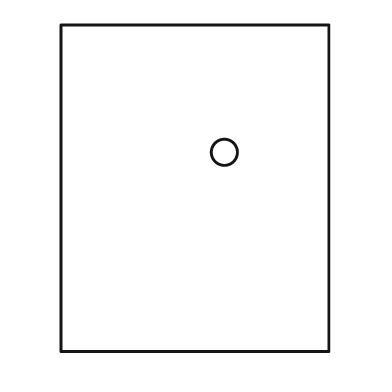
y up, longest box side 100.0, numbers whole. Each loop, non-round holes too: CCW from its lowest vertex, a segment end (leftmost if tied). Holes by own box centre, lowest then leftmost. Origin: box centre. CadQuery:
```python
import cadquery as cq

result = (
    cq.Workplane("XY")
    .moveTo(-41.0, -50.0)
    .lineTo(41.0, -50.0)
    .lineTo(41.0, 50.0)
    .lineTo(-41.0, 50.0)
    .close()
    .moveTo(9.0, 11.0)
    .circle(4.0)
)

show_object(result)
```